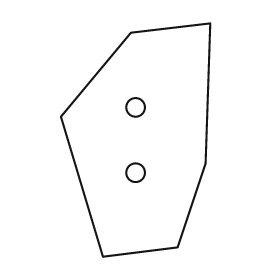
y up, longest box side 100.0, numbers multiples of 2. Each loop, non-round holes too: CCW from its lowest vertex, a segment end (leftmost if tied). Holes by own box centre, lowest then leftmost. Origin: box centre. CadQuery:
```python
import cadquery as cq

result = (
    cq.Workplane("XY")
    .moveTo(-14.0, -50.0)
    .lineTo(18.0, -46.0)
    .lineTo(30.0, -10.0)
    .lineTo(32.0, 50.0)
    .lineTo(-2.0, 46.0)
    .lineTo(-32.0, 10.0)
    .close()
    .moveTo(0.0, -14.0)
    .circle(4.0)
    .moveTo(0.0, 14.0)
    .circle(4.0)
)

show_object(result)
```